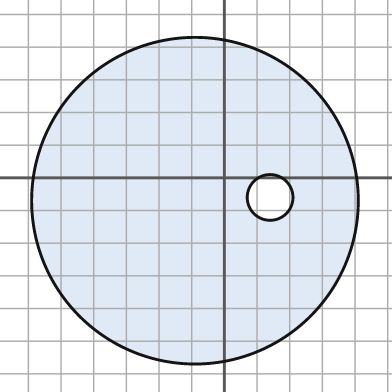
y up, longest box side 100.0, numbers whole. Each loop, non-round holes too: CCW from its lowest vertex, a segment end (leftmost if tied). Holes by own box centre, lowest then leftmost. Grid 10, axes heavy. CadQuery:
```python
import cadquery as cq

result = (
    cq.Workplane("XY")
    .moveTo(-9.0, -7.0)
    .circle(50.0)
    .moveTo(14.0, -6.0)
    .circle(7.0)
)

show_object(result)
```